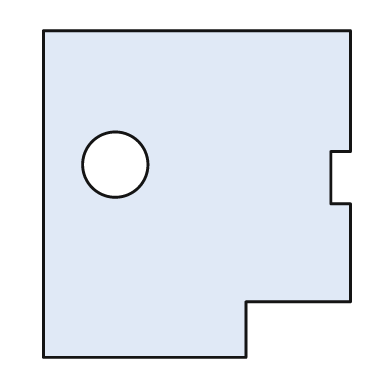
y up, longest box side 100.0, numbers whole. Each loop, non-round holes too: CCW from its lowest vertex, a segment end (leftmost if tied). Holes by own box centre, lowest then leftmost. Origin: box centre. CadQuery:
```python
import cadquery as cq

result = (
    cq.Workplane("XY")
    .moveTo(-47.0, -50.0)
    .lineTo(15.0, -50.0)
    .lineTo(15.0, -33.0)
    .lineTo(47.0, -33.0)
    .lineTo(47.0, -3.0)
    .lineTo(41.0, -3.0)
    .lineTo(41.0, 13.0)
    .lineTo(47.0, 13.0)
    .lineTo(47.0, 50.0)
    .lineTo(-47.0, 50.0)
    .close()
    .moveTo(-25.0, 9.0)
    .circle(10.0)
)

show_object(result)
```